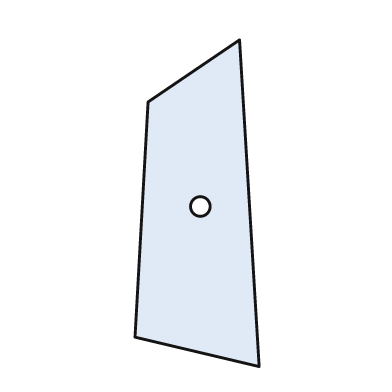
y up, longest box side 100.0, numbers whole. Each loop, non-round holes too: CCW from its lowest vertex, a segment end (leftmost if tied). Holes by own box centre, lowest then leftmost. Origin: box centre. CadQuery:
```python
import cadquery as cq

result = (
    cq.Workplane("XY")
    .moveTo(19.0, -50.0)
    .lineTo(13.0, 50.0)
    .lineTo(-15.0, 31.0)
    .lineTo(-19.0, -41.0)
    .close()
    .moveTo(1.0, -1.0)
    .circle(3.0)
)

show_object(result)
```